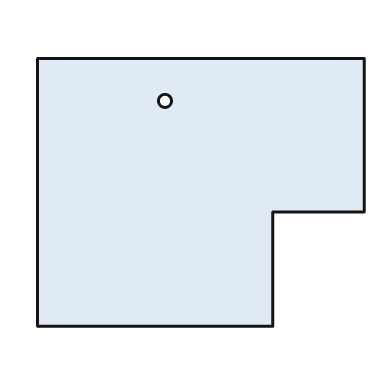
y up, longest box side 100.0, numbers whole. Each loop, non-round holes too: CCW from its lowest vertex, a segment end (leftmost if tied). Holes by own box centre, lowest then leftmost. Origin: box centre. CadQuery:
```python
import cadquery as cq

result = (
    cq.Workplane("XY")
    .moveTo(-50.0, -41.0)
    .lineTo(22.0, -41.0)
    .lineTo(22.0, -6.0)
    .lineTo(50.0, -6.0)
    .lineTo(50.0, 41.0)
    .lineTo(-50.0, 41.0)
    .close()
    .moveTo(-11.0, 28.0)
    .circle(2.0)
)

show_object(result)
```